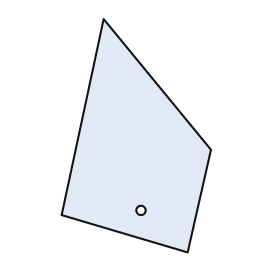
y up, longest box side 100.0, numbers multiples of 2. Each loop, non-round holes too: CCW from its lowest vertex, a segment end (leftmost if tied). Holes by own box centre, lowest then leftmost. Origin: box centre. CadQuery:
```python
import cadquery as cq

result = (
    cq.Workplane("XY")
    .moveTo(22.0, -50.0)
    .lineTo(32.0, -6.0)
    .lineTo(-14.0, 50.0)
    .lineTo(-32.0, -34.0)
    .close()
    .moveTo(2.0, -32.0)
    .circle(2.0)
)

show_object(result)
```